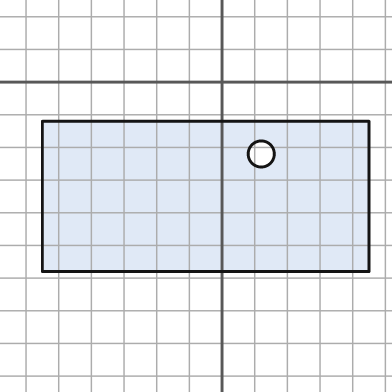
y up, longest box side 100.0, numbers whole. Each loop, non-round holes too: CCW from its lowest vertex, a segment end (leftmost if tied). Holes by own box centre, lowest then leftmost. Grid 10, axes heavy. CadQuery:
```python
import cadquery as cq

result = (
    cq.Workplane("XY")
    .moveTo(-55.0, -58.0)
    .lineTo(45.0, -58.0)
    .lineTo(45.0, -12.0)
    .lineTo(-55.0, -12.0)
    .close()
    .moveTo(12.0, -22.0)
    .circle(4.0)
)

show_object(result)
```